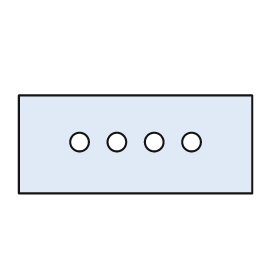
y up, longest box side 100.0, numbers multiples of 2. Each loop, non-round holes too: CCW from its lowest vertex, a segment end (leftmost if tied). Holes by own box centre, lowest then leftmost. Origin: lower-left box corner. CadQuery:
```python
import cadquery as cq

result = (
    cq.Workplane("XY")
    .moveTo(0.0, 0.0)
    .lineTo(100.0, 0.0)
    .lineTo(100.0, 42.0)
    .lineTo(0.0, 42.0)
    .close()
    .moveTo(26.0, 22.0)
    .circle(4.0)
    .moveTo(42.0, 22.0)
    .circle(4.0)
    .moveTo(58.0, 22.0)
    .circle(4.0)
    .moveTo(74.0, 22.0)
    .circle(4.0)
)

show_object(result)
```